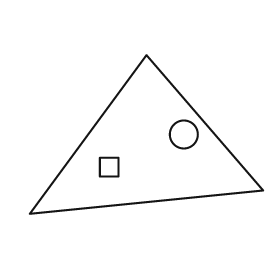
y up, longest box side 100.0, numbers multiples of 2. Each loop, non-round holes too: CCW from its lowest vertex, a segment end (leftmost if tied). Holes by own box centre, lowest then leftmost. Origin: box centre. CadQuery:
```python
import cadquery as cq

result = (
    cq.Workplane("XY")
    .moveTo(-50.0, -34.0)
    .lineTo(50.0, -24.0)
    .lineTo(0.0, 34.0)
    .close()
    .moveTo(-20.0, -18.0)
    .lineTo(-12.0, -18.0)
    .lineTo(-12.0, -10.0)
    .lineTo(-20.0, -10.0)
    .close()
    .moveTo(16.0, 0.0)
    .circle(6.0)
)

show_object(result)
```